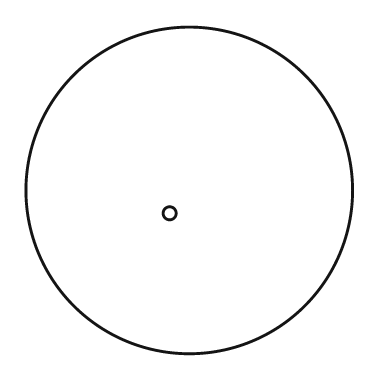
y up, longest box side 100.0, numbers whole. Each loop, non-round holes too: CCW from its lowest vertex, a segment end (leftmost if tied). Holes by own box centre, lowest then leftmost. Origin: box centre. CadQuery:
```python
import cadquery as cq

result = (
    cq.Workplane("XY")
    .moveTo(0.0, 0.0)
    .circle(50.0)
    .moveTo(-6.0, -7.0)
    .circle(2.0)
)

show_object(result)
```